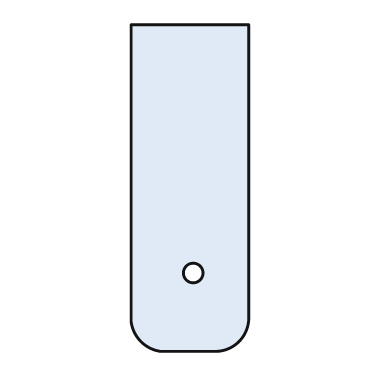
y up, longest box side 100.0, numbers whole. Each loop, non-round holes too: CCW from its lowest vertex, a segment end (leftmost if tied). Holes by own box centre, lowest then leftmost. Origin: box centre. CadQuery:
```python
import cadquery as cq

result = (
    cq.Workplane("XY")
    .moveTo(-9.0, -50.0)
    .lineTo(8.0, -50.0)
    .threePointArc((15.0, -47.0), (18.0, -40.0))
    .lineTo(18.0, 50.0)
    .lineTo(-18.0, 50.0)
    .lineTo(-18.0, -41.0)
    .threePointArc((-15.0, -47.0), (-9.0, -50.0))
    .close()
    .moveTo(1.0, -26.0)
    .circle(3.0)
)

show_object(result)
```